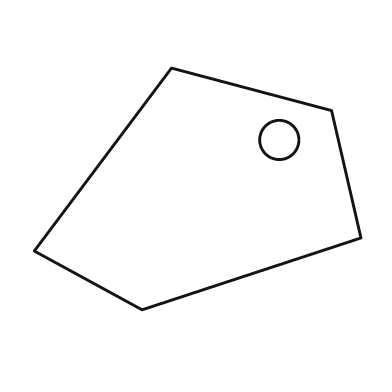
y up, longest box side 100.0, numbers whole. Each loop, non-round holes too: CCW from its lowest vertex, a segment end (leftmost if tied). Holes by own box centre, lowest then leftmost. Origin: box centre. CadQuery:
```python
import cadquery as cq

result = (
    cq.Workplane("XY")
    .moveTo(-17.0, -37.0)
    .lineTo(50.0, -15.0)
    .lineTo(41.0, 24.0)
    .lineTo(-8.0, 37.0)
    .lineTo(-50.0, -19.0)
    .close()
    .moveTo(25.0, 15.0)
    .circle(6.0)
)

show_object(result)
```